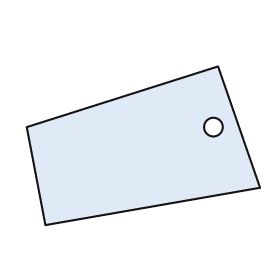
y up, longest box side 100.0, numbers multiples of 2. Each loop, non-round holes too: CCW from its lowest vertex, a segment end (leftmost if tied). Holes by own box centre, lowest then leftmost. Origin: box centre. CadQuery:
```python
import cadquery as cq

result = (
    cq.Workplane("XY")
    .moveTo(-42.0, -34.0)
    .lineTo(50.0, -18.0)
    .lineTo(32.0, 34.0)
    .lineTo(-50.0, 8.0)
    .close()
    .moveTo(30.0, 8.0)
    .circle(4.0)
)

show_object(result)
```